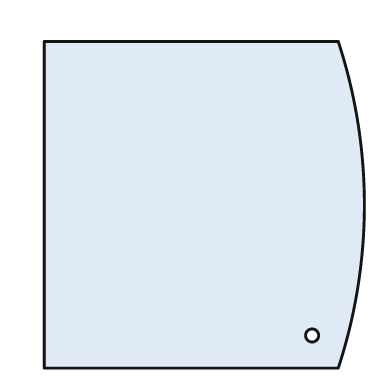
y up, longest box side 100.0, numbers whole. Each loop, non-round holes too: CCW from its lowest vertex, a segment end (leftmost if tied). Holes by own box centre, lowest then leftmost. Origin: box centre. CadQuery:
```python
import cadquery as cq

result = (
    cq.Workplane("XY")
    .moveTo(-49.0, -50.0)
    .lineTo(41.0, -50.0)
    .threePointArc((49.0, 0.0), (41.0, 50.0))
    .lineTo(-49.0, 50.0)
    .close()
    .moveTo(33.0, -40.0)
    .circle(2.0)
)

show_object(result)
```